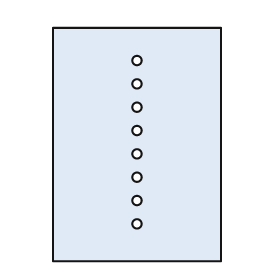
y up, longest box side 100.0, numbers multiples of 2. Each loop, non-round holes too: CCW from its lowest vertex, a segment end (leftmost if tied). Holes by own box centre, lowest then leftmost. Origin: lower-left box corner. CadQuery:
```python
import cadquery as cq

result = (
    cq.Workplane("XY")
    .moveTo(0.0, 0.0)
    .lineTo(72.0, 0.0)
    .lineTo(72.0, 100.0)
    .lineTo(0.0, 100.0)
    .close()
    .moveTo(36.0, 16.0)
    .circle(2.0)
    .moveTo(36.0, 26.0)
    .circle(2.0)
    .moveTo(36.0, 36.0)
    .circle(2.0)
    .moveTo(36.0, 46.0)
    .circle(2.0)
    .moveTo(36.0, 56.0)
    .circle(2.0)
    .moveTo(36.0, 66.0)
    .circle(2.0)
    .moveTo(36.0, 76.0)
    .circle(2.0)
    .moveTo(36.0, 86.0)
    .circle(2.0)
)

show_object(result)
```